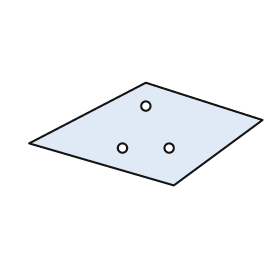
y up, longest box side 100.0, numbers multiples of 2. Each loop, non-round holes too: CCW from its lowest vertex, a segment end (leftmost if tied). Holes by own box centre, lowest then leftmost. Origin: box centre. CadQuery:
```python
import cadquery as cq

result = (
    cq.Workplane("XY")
    .moveTo(12.0, -22.0)
    .lineTo(50.0, 6.0)
    .lineTo(0.0, 22.0)
    .lineTo(-50.0, -4.0)
    .close()
    .moveTo(-10.0, -6.0)
    .circle(2.0)
    .moveTo(10.0, -6.0)
    .circle(2.0)
    .moveTo(0.0, 12.0)
    .circle(2.0)
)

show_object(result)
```